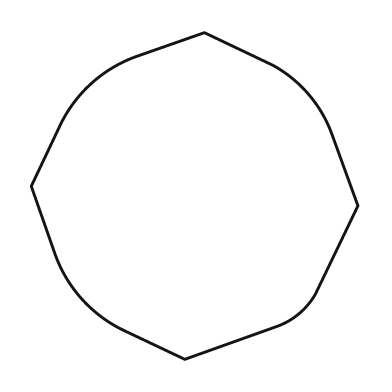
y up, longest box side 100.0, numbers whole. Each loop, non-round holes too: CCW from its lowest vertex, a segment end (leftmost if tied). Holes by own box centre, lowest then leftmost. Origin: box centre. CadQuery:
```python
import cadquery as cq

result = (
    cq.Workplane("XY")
    .moveTo(-3.0, -50.0)
    .lineTo(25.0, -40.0)
    .threePointArc((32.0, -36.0), (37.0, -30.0))
    .lineTo(50.0, -3.0)
    .lineTo(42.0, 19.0)
    .threePointArc((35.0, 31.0), (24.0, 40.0))
    .lineTo(3.0, 50.0)
    .lineTo(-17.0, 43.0)
    .threePointArc((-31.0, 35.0), (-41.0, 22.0))
    .lineTo(-50.0, 3.0)
    .lineTo(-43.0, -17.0)
    .threePointArc((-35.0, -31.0), (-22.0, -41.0))
    .close()
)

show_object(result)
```